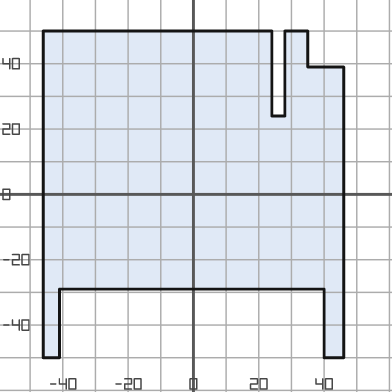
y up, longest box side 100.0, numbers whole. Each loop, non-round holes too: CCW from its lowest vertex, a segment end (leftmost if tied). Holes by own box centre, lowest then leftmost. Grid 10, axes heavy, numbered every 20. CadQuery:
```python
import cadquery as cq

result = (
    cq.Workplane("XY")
    .moveTo(-46.0, -50.0)
    .lineTo(-41.0, -50.0)
    .lineTo(-41.0, -29.0)
    .lineTo(40.0, -29.0)
    .lineTo(40.0, -50.0)
    .lineTo(46.0, -50.0)
    .lineTo(46.0, 39.0)
    .lineTo(35.0, 39.0)
    .lineTo(35.0, 50.0)
    .lineTo(28.0, 50.0)
    .lineTo(28.0, 24.0)
    .lineTo(24.0, 24.0)
    .lineTo(24.0, 50.0)
    .lineTo(-46.0, 50.0)
    .close()
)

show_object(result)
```